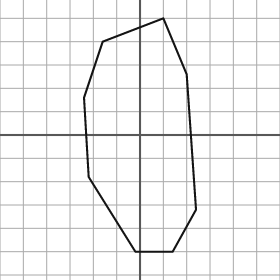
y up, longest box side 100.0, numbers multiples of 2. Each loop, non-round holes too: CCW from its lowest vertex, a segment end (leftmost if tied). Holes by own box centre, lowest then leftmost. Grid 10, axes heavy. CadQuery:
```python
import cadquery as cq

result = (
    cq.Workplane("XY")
    .moveTo(-2.0, -50.0)
    .lineTo(14.0, -50.0)
    .lineTo(24.0, -32.0)
    .lineTo(20.0, 26.0)
    .lineTo(10.0, 50.0)
    .lineTo(-16.0, 40.0)
    .lineTo(-24.0, 16.0)
    .lineTo(-22.0, -18.0)
    .close()
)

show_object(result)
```